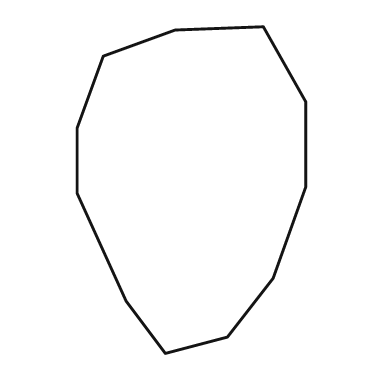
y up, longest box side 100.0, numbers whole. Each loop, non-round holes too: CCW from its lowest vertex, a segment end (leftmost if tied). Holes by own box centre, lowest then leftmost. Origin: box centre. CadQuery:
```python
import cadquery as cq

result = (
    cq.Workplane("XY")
    .moveTo(-8.0, -50.0)
    .lineTo(11.0, -45.0)
    .lineTo(25.0, -27.0)
    .lineTo(35.0, 1.0)
    .lineTo(35.0, 27.0)
    .lineTo(22.0, 50.0)
    .lineTo(-5.0, 49.0)
    .lineTo(-27.0, 41.0)
    .lineTo(-35.0, 19.0)
    .lineTo(-35.0, -1.0)
    .lineTo(-20.0, -34.0)
    .close()
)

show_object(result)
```